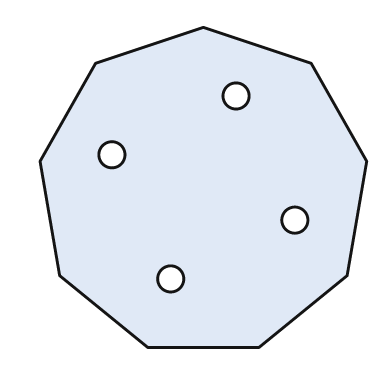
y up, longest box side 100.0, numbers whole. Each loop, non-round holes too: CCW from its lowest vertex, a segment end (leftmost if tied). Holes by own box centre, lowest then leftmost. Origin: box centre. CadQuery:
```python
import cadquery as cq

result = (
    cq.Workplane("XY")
    .moveTo(-17.0, -49.0)
    .lineTo(17.0, -49.0)
    .lineTo(44.0, -27.0)
    .lineTo(50.0, 8.0)
    .lineTo(33.0, 38.0)
    .lineTo(0.0, 49.0)
    .lineTo(-33.0, 38.0)
    .lineTo(-50.0, 8.0)
    .lineTo(-44.0, -27.0)
    .close()
    .moveTo(-10.0, -28.0)
    .circle(4.0)
    .moveTo(28.0, -10.0)
    .circle(4.0)
    .moveTo(-28.0, 10.0)
    .circle(4.0)
    .moveTo(10.0, 28.0)
    .circle(4.0)
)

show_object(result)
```